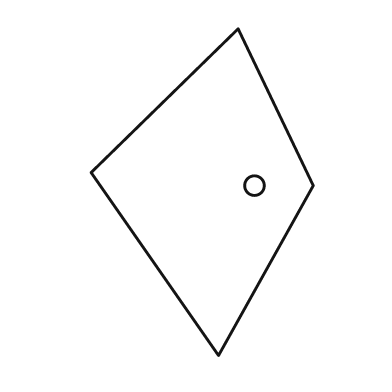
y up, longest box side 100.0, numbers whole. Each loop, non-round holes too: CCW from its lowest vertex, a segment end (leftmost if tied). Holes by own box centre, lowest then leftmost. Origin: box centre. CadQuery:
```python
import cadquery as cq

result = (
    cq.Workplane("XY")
    .moveTo(5.0, -50.0)
    .lineTo(34.0, 2.0)
    .lineTo(11.0, 50.0)
    .lineTo(-34.0, 6.0)
    .close()
    .moveTo(16.0, 2.0)
    .circle(3.0)
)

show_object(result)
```